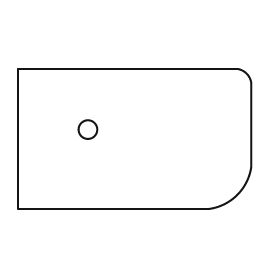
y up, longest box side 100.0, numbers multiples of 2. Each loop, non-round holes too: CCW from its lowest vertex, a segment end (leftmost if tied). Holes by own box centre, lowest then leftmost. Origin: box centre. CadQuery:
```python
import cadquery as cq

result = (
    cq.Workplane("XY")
    .moveTo(-50.0, -30.0)
    .lineTo(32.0, -30.0)
    .threePointArc((44.0, -24.0), (50.0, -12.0))
    .lineTo(50.0, 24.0)
    .threePointArc((48.0, 28.0), (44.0, 30.0))
    .lineTo(-50.0, 30.0)
    .close()
    .moveTo(-20.0, 4.0)
    .circle(4.0)
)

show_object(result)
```